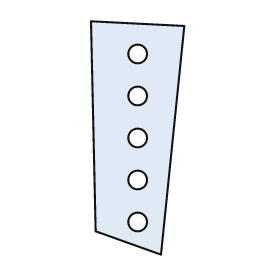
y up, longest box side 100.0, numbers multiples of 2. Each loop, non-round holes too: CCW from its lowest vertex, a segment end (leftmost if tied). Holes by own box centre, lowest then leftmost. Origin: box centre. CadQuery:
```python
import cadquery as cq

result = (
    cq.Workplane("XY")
    .moveTo(10.0, -50.0)
    .lineTo(20.0, 48.0)
    .lineTo(-20.0, 50.0)
    .lineTo(-18.0, -40.0)
    .close()
    .moveTo(0.0, -36.0)
    .circle(4.0)
    .moveTo(0.0, -18.0)
    .circle(4.0)
    .moveTo(0.0, 0.0)
    .circle(4.0)
    .moveTo(0.0, 18.0)
    .circle(4.0)
    .moveTo(0.0, 36.0)
    .circle(4.0)
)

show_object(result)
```